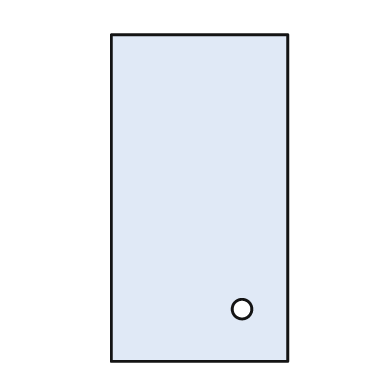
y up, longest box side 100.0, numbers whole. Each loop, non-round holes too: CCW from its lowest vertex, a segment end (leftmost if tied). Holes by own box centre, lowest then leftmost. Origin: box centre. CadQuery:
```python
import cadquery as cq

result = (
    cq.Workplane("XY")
    .moveTo(-27.0, -50.0)
    .lineTo(27.0, -50.0)
    .lineTo(27.0, 50.0)
    .lineTo(-27.0, 50.0)
    .close()
    .moveTo(13.0, -34.0)
    .circle(3.0)
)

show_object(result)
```